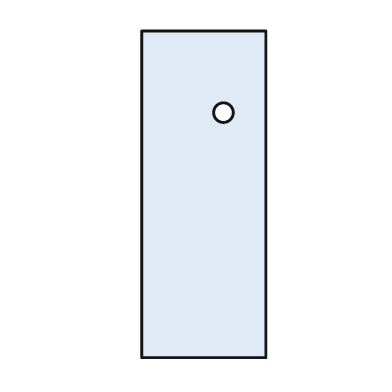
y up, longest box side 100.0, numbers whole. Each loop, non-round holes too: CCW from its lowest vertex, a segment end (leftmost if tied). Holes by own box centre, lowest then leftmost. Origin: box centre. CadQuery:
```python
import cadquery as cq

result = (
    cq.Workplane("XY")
    .moveTo(-19.0, -50.0)
    .lineTo(19.0, -50.0)
    .lineTo(19.0, 50.0)
    .lineTo(-19.0, 50.0)
    .close()
    .moveTo(6.0, 25.0)
    .circle(3.0)
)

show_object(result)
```